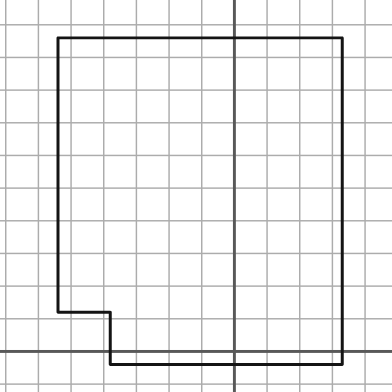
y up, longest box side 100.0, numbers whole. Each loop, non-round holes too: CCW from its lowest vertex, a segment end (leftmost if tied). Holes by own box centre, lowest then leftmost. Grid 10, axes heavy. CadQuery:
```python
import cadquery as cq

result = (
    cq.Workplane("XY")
    .moveTo(-38.0, -4.0)
    .lineTo(33.0, -4.0)
    .lineTo(33.0, 96.0)
    .lineTo(-54.0, 96.0)
    .lineTo(-54.0, 12.0)
    .lineTo(-38.0, 12.0)
    .close()
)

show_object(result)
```